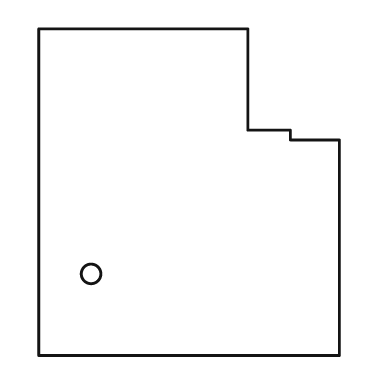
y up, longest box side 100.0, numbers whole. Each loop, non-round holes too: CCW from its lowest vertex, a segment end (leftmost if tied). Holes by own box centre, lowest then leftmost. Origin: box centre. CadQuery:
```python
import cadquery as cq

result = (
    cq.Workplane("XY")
    .moveTo(-46.0, -50.0)
    .lineTo(46.0, -50.0)
    .lineTo(46.0, 16.0)
    .lineTo(31.0, 16.0)
    .lineTo(31.0, 19.0)
    .lineTo(18.0, 19.0)
    .lineTo(18.0, 50.0)
    .lineTo(-46.0, 50.0)
    .close()
    .moveTo(-30.0, -25.0)
    .circle(3.0)
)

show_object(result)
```